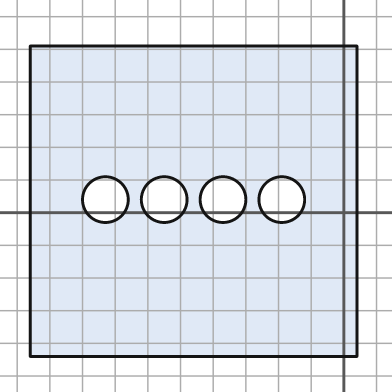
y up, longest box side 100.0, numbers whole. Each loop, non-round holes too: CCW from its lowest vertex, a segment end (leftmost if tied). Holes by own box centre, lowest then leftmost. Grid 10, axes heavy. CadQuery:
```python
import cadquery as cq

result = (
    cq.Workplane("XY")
    .moveTo(-96.0, -44.0)
    .lineTo(4.0, -44.0)
    .lineTo(4.0, 51.0)
    .lineTo(-96.0, 51.0)
    .close()
    .moveTo(-73.0, 4.0)
    .circle(7.0)
    .moveTo(-55.0, 4.0)
    .circle(7.0)
    .moveTo(-37.0, 4.0)
    .circle(7.0)
    .moveTo(-19.0, 4.0)
    .circle(7.0)
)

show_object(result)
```